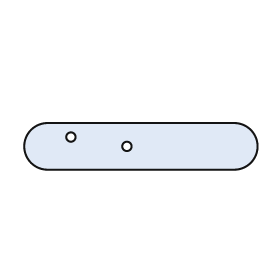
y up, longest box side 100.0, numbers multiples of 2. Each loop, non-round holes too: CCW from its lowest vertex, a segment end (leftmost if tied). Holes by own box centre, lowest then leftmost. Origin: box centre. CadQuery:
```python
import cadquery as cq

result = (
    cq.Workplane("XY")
    .moveTo(-40.0, -10.0)
    .lineTo(40.0, -10.0)
    .threePointArc((50.0, 0.0), (40.0, 10.0))
    .lineTo(-40.0, 10.0)
    .threePointArc((-50.0, 0.0), (-40.0, -10.0))
    .close()
    .moveTo(-6.0, 0.0)
    .circle(2.0)
    .moveTo(-30.0, 4.0)
    .circle(2.0)
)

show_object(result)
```